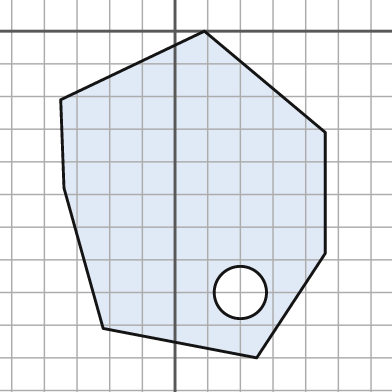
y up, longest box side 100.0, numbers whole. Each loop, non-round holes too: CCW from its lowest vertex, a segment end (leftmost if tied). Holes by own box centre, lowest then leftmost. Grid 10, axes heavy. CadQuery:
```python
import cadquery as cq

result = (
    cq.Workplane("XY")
    .moveTo(25.0, -100.0)
    .lineTo(46.0, -68.0)
    .lineTo(46.0, -31.0)
    .lineTo(9.0, 0.0)
    .lineTo(-35.0, -21.0)
    .lineTo(-34.0, -48.0)
    .lineTo(-22.0, -91.0)
    .close()
    .moveTo(20.0, -80.0)
    .circle(8.0)
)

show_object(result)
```